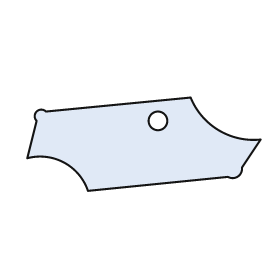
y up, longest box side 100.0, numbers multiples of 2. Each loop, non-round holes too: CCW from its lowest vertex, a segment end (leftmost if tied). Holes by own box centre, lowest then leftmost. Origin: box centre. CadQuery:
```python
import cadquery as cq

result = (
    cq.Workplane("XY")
    .moveTo(-24.0, -20.0)
    .lineTo(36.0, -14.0)
    .threePointArc((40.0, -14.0), (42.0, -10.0))
    .lineTo(50.0, 2.0)
    .threePointArc((32.0, 6.0), (20.0, 20.0))
    .lineTo(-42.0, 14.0)
    .threePointArc((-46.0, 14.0), (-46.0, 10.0))
    .lineTo(-50.0, -6.0)
    .threePointArc((-34.0, -8.0), (-24.0, -20.0))
    .close()
    .moveTo(6.0, 10.0)
    .circle(4.0)
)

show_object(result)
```